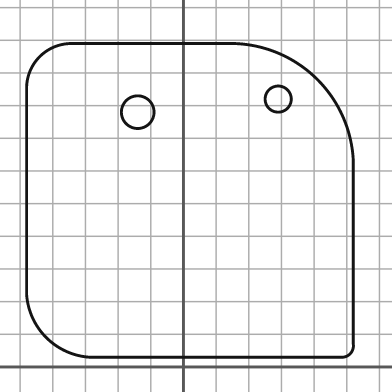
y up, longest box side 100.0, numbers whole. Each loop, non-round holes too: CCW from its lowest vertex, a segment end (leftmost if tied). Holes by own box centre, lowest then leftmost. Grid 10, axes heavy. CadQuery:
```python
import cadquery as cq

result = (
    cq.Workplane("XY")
    .moveTo(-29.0, 3.0)
    .lineTo(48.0, 3.0)
    .threePointArc((51.0, 4.0), (52.0, 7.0))
    .lineTo(52.0, 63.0)
    .threePointArc((41.0, 88.0), (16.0, 99.0))
    .lineTo(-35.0, 99.0)
    .threePointArc((-44.0, 95.0), (-48.0, 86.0))
    .lineTo(-48.0, 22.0)
    .threePointArc((-42.0, 9.0), (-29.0, 3.0))
    .close()
    .moveTo(-14.0, 78.0)
    .circle(5.0)
    .moveTo(29.0, 82.0)
    .circle(4.0)
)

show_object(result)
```